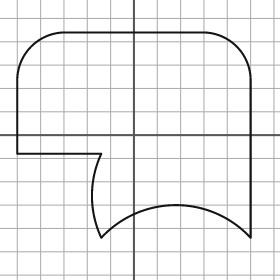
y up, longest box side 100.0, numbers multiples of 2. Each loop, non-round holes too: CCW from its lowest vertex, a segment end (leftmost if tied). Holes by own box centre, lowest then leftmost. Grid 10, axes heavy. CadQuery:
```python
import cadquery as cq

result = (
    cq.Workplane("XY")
    .moveTo(-14.0, -44.0)
    .threePointArc((18.0, -30.0), (50.0, -44.0))
    .lineTo(50.0, 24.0)
    .threePointArc((44.0, 38.0), (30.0, 44.0))
    .lineTo(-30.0, 44.0)
    .threePointArc((-44.0, 38.0), (-50.0, 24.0))
    .lineTo(-50.0, -8.0)
    .lineTo(-14.0, -8.0)
    .threePointArc((-18.0, -26.0), (-14.0, -44.0))
    .close()
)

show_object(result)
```